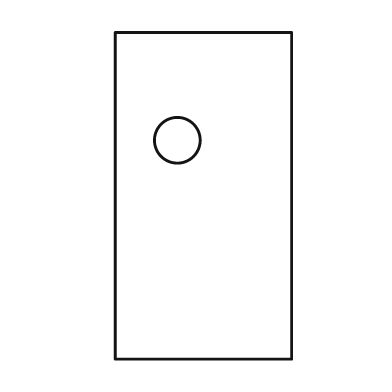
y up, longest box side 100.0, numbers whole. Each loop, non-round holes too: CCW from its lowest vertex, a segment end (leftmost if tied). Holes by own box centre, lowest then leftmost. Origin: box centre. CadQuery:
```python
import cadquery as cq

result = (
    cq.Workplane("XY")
    .moveTo(-27.0, -50.0)
    .lineTo(27.0, -50.0)
    .lineTo(27.0, 50.0)
    .lineTo(-27.0, 50.0)
    .close()
    .moveTo(-8.0, 17.0)
    .circle(7.0)
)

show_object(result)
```